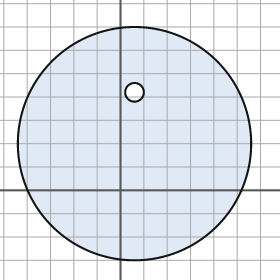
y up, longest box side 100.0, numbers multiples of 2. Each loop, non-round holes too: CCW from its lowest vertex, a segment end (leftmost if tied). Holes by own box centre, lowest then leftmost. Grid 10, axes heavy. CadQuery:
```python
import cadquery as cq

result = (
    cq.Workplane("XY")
    .moveTo(6.0, 20.0)
    .circle(50.0)
    .moveTo(6.0, 42.0)
    .circle(4.0)
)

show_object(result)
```